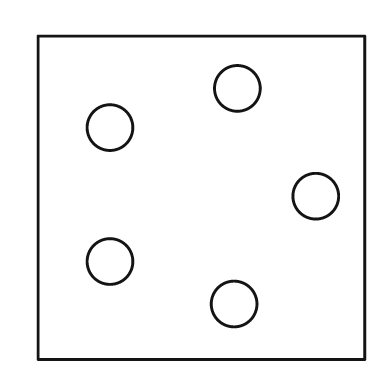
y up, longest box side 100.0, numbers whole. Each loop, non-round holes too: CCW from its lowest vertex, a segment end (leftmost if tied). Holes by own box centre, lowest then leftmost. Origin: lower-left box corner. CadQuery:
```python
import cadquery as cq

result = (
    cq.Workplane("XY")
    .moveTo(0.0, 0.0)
    .lineTo(100.0, 0.0)
    .lineTo(100.0, 99.0)
    .lineTo(0.0, 99.0)
    .close()
    .moveTo(60.0, 17.0)
    .circle(7.0)
    .moveTo(22.0, 30.0)
    .circle(7.0)
    .moveTo(85.0, 50.0)
    .circle(7.0)
    .moveTo(22.0, 71.0)
    .circle(7.0)
    .moveTo(61.0, 83.0)
    .circle(7.0)
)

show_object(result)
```